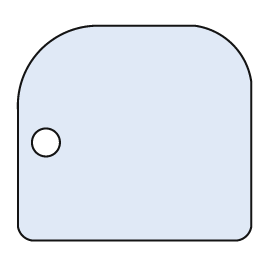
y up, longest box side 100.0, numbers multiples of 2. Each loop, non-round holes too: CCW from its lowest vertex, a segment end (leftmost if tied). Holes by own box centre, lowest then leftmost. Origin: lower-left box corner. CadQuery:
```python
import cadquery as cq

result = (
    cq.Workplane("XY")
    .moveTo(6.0, 0.0)
    .lineTo(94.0, 0.0)
    .threePointArc((98.0, 2.0), (100.0, 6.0))
    .lineTo(100.0, 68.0)
    .threePointArc((92.0, 84.0), (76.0, 92.0))
    .lineTo(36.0, 92.0)
    .threePointArc((10.0, 82.0), (0.0, 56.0))
    .lineTo(0.0, 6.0)
    .threePointArc((2.0, 2.0), (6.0, 0.0))
    .close()
    .moveTo(12.0, 42.0)
    .circle(6.0)
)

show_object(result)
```